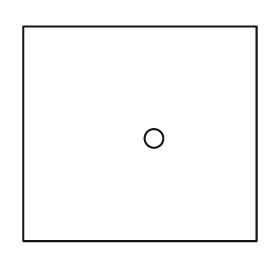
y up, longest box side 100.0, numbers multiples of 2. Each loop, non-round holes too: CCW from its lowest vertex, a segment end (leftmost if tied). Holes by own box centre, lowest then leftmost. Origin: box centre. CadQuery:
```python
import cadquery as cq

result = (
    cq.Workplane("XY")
    .moveTo(-50.0, -46.0)
    .lineTo(50.0, -46.0)
    .lineTo(50.0, 46.0)
    .lineTo(-50.0, 46.0)
    .close()
    .moveTo(6.0, -2.0)
    .circle(4.0)
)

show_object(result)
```